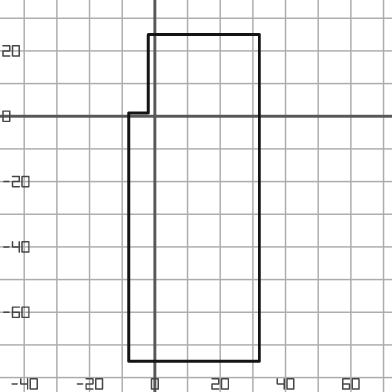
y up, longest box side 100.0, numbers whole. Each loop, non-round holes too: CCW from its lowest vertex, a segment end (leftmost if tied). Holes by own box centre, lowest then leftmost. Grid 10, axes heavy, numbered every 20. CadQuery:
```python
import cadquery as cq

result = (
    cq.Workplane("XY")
    .moveTo(-8.0, -75.0)
    .lineTo(32.0, -75.0)
    .lineTo(32.0, 25.0)
    .lineTo(-2.0, 25.0)
    .lineTo(-2.0, 1.0)
    .lineTo(-8.0, 1.0)
    .close()
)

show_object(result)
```